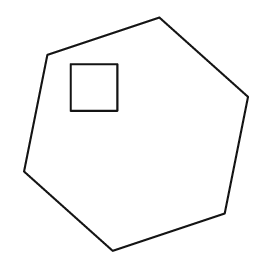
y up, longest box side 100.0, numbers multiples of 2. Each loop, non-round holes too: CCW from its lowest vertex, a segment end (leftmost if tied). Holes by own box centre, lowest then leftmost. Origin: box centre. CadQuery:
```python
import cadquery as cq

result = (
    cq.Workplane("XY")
    .moveTo(-10.0, -50.0)
    .lineTo(38.0, -34.0)
    .lineTo(48.0, 16.0)
    .lineTo(10.0, 50.0)
    .lineTo(-38.0, 34.0)
    .lineTo(-48.0, -16.0)
    .close()
    .moveTo(-28.0, 10.0)
    .lineTo(-8.0, 10.0)
    .lineTo(-8.0, 30.0)
    .lineTo(-28.0, 30.0)
    .close()
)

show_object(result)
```